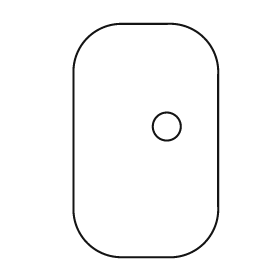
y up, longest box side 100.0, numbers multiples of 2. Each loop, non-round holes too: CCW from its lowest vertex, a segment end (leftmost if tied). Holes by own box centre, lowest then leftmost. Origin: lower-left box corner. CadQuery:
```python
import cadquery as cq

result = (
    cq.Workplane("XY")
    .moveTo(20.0, 0.0)
    .lineTo(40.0, 0.0)
    .threePointArc((56.0, 6.0), (62.0, 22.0))
    .lineTo(62.0, 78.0)
    .threePointArc((56.0, 94.0), (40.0, 100.0))
    .lineTo(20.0, 100.0)
    .threePointArc((6.0, 94.0), (0.0, 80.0))
    .lineTo(0.0, 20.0)
    .threePointArc((6.0, 6.0), (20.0, 0.0))
    .close()
    .moveTo(40.0, 56.0)
    .circle(6.0)
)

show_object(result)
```